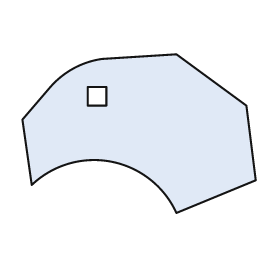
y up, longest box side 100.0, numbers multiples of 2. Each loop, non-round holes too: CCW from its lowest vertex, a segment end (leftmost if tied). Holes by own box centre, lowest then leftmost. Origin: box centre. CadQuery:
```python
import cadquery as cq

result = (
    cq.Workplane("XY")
    .moveTo(16.0, -34.0)
    .lineTo(50.0, -20.0)
    .lineTo(46.0, 12.0)
    .lineTo(16.0, 34.0)
    .lineTo(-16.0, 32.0)
    .threePointArc((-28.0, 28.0), (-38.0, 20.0))
    .lineTo(-50.0, 6.0)
    .lineTo(-46.0, -22.0)
    .threePointArc((-12.0, -12.0), (16.0, -34.0))
    .close()
    .moveTo(-22.0, 12.0)
    .lineTo(-14.0, 12.0)
    .lineTo(-14.0, 20.0)
    .lineTo(-22.0, 20.0)
    .close()
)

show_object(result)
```